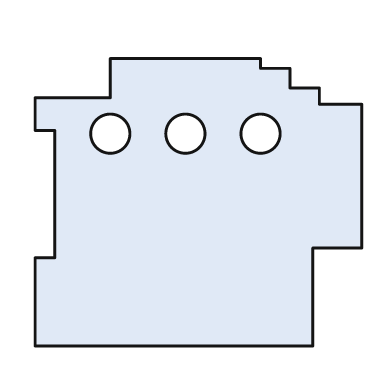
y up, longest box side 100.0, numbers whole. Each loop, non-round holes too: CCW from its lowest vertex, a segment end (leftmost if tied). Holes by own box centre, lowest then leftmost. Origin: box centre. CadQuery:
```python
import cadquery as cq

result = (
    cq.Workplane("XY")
    .moveTo(-50.0, -44.0)
    .lineTo(35.0, -44.0)
    .lineTo(35.0, -14.0)
    .lineTo(50.0, -14.0)
    .lineTo(50.0, 30.0)
    .lineTo(37.0, 30.0)
    .lineTo(37.0, 35.0)
    .lineTo(28.0, 35.0)
    .lineTo(28.0, 41.0)
    .lineTo(19.0, 41.0)
    .lineTo(19.0, 44.0)
    .lineTo(-27.0, 44.0)
    .lineTo(-27.0, 32.0)
    .lineTo(-50.0, 32.0)
    .lineTo(-50.0, 22.0)
    .lineTo(-44.0, 22.0)
    .lineTo(-44.0, -17.0)
    .lineTo(-50.0, -17.0)
    .close()
    .moveTo(-27.0, 21.0)
    .circle(6.0)
    .moveTo(-4.0, 21.0)
    .circle(6.0)
    .moveTo(19.0, 21.0)
    .circle(6.0)
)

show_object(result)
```